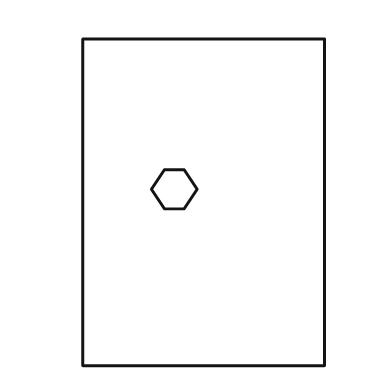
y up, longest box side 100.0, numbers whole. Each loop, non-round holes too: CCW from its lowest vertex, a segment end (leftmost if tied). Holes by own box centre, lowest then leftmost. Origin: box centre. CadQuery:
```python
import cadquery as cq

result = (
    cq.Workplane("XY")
    .moveTo(-37.0, -50.0)
    .lineTo(37.0, -50.0)
    .lineTo(37.0, 50.0)
    .lineTo(-37.0, 50.0)
    .close()
    .moveTo(-12.0, -2.0)
    .lineTo(-6.0, -2.0)
    .lineTo(-2.0, 4.0)
    .lineTo(-6.0, 10.0)
    .lineTo(-12.0, 10.0)
    .lineTo(-16.0, 4.0)
    .close()
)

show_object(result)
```